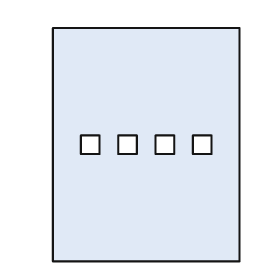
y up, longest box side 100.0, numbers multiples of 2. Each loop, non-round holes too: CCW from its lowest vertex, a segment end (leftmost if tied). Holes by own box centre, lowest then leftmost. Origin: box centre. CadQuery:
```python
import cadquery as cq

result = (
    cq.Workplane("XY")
    .moveTo(-40.0, -50.0)
    .lineTo(40.0, -50.0)
    .lineTo(40.0, 50.0)
    .lineTo(-40.0, 50.0)
    .close()
    .moveTo(-28.0, -4.0)
    .lineTo(-20.0, -4.0)
    .lineTo(-20.0, 4.0)
    .lineTo(-28.0, 4.0)
    .close()
    .moveTo(-12.0, -4.0)
    .lineTo(-4.0, -4.0)
    .lineTo(-4.0, 4.0)
    .lineTo(-12.0, 4.0)
    .close()
    .moveTo(4.0, -4.0)
    .lineTo(12.0, -4.0)
    .lineTo(12.0, 4.0)
    .lineTo(4.0, 4.0)
    .close()
    .moveTo(20.0, -4.0)
    .lineTo(28.0, -4.0)
    .lineTo(28.0, 4.0)
    .lineTo(20.0, 4.0)
    .close()
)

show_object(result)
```